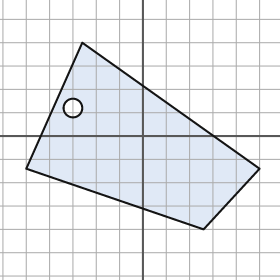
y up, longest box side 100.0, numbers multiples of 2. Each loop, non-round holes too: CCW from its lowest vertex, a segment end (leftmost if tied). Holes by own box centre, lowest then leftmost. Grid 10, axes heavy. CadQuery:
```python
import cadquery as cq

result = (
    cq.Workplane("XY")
    .moveTo(26.0, -40.0)
    .lineTo(50.0, -14.0)
    .lineTo(-26.0, 40.0)
    .lineTo(-50.0, -14.0)
    .close()
    .moveTo(-30.0, 12.0)
    .circle(4.0)
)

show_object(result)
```